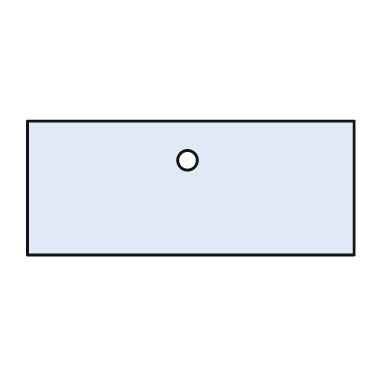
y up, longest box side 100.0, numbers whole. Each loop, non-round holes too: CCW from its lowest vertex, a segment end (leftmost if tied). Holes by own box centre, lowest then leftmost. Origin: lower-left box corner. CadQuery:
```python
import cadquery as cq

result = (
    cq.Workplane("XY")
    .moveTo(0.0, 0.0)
    .lineTo(100.0, 0.0)
    .lineTo(100.0, 41.0)
    .lineTo(0.0, 41.0)
    .close()
    .moveTo(49.0, 29.0)
    .circle(3.0)
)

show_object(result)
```